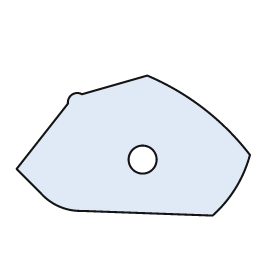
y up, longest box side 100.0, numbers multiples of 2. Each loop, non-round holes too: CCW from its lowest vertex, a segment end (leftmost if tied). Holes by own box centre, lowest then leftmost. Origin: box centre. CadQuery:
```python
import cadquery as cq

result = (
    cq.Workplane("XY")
    .moveTo(34.0, -30.0)
    .threePointArc((44.0, -18.0), (50.0, -4.0))
    .threePointArc((30.0, 16.0), (6.0, 30.0))
    .lineTo(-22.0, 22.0)
    .threePointArc((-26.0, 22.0), (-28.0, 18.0))
    .lineTo(-50.0, -10.0)
    .lineTo(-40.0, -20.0)
    .threePointArc((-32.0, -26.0), (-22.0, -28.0))
    .close()
    .moveTo(4.0, -6.0)
    .circle(6.0)
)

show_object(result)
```